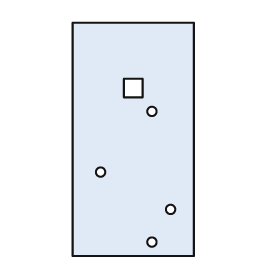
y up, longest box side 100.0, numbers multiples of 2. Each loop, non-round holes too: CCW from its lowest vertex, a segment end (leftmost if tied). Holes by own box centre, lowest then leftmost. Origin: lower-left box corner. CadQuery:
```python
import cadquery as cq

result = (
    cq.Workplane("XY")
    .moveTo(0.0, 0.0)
    .lineTo(52.0, 0.0)
    .lineTo(52.0, 100.0)
    .lineTo(0.0, 100.0)
    .close()
    .moveTo(34.0, 6.0)
    .circle(2.0)
    .moveTo(42.0, 20.0)
    .circle(2.0)
    .moveTo(12.0, 36.0)
    .circle(2.0)
    .moveTo(34.0, 62.0)
    .circle(2.0)
    .moveTo(22.0, 68.0)
    .lineTo(30.0, 68.0)
    .lineTo(30.0, 76.0)
    .lineTo(22.0, 76.0)
    .close()
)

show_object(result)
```